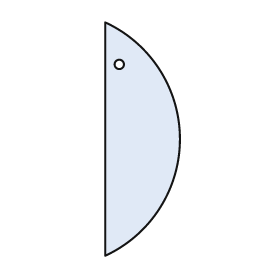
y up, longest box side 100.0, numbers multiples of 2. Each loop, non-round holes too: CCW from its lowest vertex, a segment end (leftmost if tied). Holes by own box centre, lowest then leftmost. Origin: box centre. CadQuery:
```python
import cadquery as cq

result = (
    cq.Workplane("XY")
    .moveTo(-16.0, -50.0)
    .threePointArc((16.0, 0.0), (-16.0, 50.0))
    .close()
    .moveTo(-10.0, 32.0)
    .circle(2.0)
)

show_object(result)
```